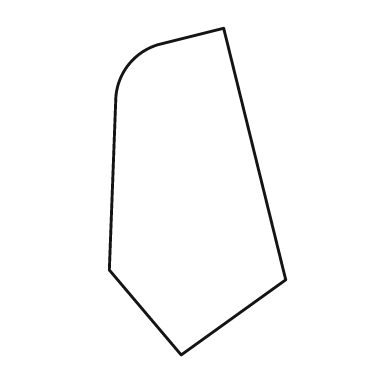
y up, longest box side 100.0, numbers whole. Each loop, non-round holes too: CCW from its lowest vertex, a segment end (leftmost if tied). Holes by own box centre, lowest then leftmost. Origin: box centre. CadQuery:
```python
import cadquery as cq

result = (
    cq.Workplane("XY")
    .moveTo(-5.0, -50.0)
    .lineTo(27.0, -27.0)
    .lineTo(8.0, 50.0)
    .lineTo(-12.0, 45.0)
    .threePointArc((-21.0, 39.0), (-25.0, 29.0))
    .lineTo(-27.0, -24.0)
    .close()
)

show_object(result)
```